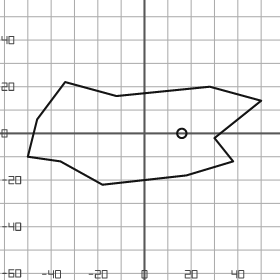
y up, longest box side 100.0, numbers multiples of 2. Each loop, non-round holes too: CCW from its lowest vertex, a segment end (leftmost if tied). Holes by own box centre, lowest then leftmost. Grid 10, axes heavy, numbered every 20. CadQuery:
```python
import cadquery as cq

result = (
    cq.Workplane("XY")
    .moveTo(-18.0, -22.0)
    .lineTo(18.0, -18.0)
    .lineTo(38.0, -12.0)
    .lineTo(30.0, -2.0)
    .lineTo(50.0, 14.0)
    .lineTo(28.0, 20.0)
    .lineTo(-12.0, 16.0)
    .lineTo(-34.0, 22.0)
    .lineTo(-46.0, 6.0)
    .lineTo(-50.0, -10.0)
    .lineTo(-36.0, -12.0)
    .close()
    .moveTo(16.0, 0.0)
    .circle(2.0)
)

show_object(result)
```